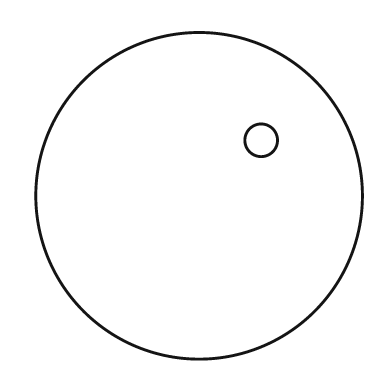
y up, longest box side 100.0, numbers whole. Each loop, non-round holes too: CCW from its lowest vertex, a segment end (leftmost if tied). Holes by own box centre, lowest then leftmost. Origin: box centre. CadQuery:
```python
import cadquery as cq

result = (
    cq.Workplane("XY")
    .moveTo(0.0, 0.0)
    .circle(50.0)
    .moveTo(19.0, 17.0)
    .circle(5.0)
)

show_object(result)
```